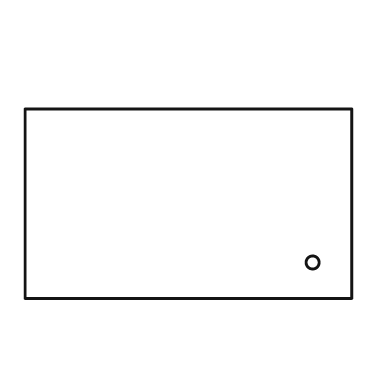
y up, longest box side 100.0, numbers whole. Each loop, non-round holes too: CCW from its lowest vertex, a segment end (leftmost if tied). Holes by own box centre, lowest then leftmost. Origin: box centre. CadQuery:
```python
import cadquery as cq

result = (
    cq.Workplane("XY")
    .moveTo(-50.0, -29.0)
    .lineTo(50.0, -29.0)
    .lineTo(50.0, 29.0)
    .lineTo(-50.0, 29.0)
    .close()
    .moveTo(38.0, -18.0)
    .circle(2.0)
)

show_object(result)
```